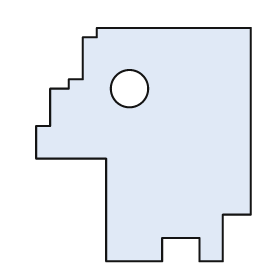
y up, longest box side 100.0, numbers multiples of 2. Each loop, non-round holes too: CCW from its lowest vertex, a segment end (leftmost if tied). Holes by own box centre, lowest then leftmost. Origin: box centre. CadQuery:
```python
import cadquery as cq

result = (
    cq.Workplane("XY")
    .moveTo(-16.0, -50.0)
    .lineTo(8.0, -50.0)
    .lineTo(8.0, -40.0)
    .lineTo(24.0, -40.0)
    .lineTo(24.0, -50.0)
    .lineTo(34.0, -50.0)
    .lineTo(34.0, -30.0)
    .lineTo(46.0, -30.0)
    .lineTo(46.0, 50.0)
    .lineTo(-20.0, 50.0)
    .lineTo(-20.0, 46.0)
    .lineTo(-26.0, 46.0)
    .lineTo(-26.0, 28.0)
    .lineTo(-32.0, 28.0)
    .lineTo(-32.0, 24.0)
    .lineTo(-40.0, 24.0)
    .lineTo(-40.0, 8.0)
    .lineTo(-46.0, 8.0)
    .lineTo(-46.0, -6.0)
    .lineTo(-16.0, -6.0)
    .close()
    .moveTo(-6.0, 24.0)
    .circle(8.0)
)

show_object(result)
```